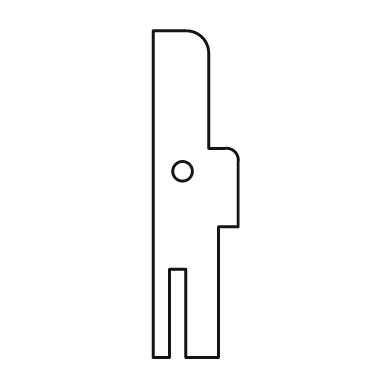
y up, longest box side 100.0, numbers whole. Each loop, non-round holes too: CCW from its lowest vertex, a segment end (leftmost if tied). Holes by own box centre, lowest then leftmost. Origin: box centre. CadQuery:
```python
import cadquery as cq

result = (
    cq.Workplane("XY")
    .moveTo(-13.0, -50.0)
    .lineTo(-8.0, -50.0)
    .lineTo(-8.0, -23.0)
    .lineTo(-3.0, -23.0)
    .lineTo(-3.0, -50.0)
    .lineTo(7.0, -50.0)
    .lineTo(7.0, -10.0)
    .lineTo(13.0, -10.0)
    .lineTo(13.0, 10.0)
    .threePointArc((12.0, 13.0), (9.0, 14.0))
    .lineTo(4.0, 14.0)
    .lineTo(4.0, 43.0)
    .threePointArc((2.0, 48.0), (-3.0, 50.0))
    .lineTo(-13.0, 50.0)
    .close()
    .moveTo(-4.0, 7.0)
    .circle(3.0)
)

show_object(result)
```